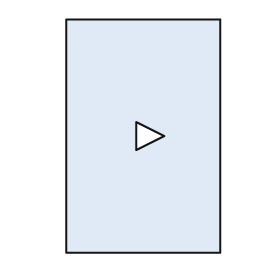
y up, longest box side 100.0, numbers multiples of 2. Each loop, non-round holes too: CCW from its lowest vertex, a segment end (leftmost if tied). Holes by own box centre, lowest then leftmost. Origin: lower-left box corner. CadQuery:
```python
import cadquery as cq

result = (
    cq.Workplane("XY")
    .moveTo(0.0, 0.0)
    .lineTo(66.0, 0.0)
    .lineTo(66.0, 100.0)
    .lineTo(0.0, 100.0)
    .close()
    .moveTo(30.0, 44.0)
    .lineTo(42.0, 50.0)
    .lineTo(30.0, 56.0)
    .close()
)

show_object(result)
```